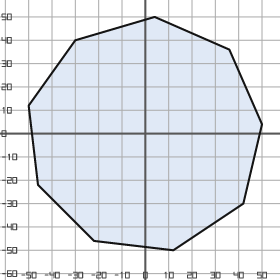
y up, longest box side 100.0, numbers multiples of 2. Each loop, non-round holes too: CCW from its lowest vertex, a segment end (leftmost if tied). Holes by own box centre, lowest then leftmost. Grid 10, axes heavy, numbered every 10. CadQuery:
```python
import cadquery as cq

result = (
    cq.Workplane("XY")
    .moveTo(12.0, -50.0)
    .lineTo(42.0, -30.0)
    .lineTo(50.0, 4.0)
    .lineTo(36.0, 36.0)
    .lineTo(4.0, 50.0)
    .lineTo(-30.0, 40.0)
    .lineTo(-50.0, 12.0)
    .lineTo(-46.0, -22.0)
    .lineTo(-22.0, -46.0)
    .close()
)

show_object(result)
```